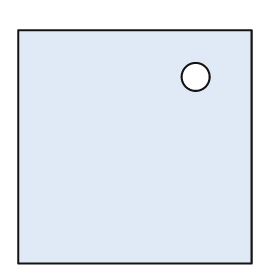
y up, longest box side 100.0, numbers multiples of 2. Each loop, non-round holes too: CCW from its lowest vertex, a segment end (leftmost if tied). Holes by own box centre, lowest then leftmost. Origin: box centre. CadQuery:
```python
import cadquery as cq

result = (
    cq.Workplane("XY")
    .moveTo(-50.0, -50.0)
    .lineTo(50.0, -50.0)
    .lineTo(50.0, 50.0)
    .lineTo(-50.0, 50.0)
    .close()
    .moveTo(26.0, 30.0)
    .circle(6.0)
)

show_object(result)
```